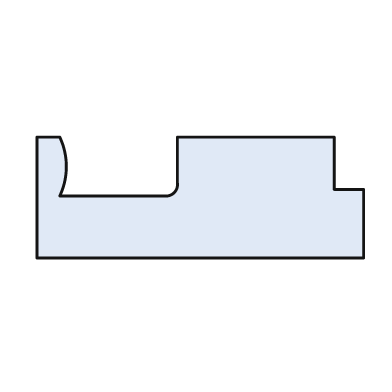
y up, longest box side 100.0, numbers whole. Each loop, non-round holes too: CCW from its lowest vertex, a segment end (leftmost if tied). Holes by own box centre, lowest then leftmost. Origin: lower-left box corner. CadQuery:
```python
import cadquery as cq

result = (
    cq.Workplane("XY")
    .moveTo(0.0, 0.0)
    .lineTo(100.0, 0.0)
    .lineTo(100.0, 21.0)
    .lineTo(91.0, 21.0)
    .lineTo(91.0, 37.0)
    .lineTo(43.0, 37.0)
    .lineTo(43.0, 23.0)
    .threePointArc((42.0, 20.0), (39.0, 19.0))
    .lineTo(7.0, 19.0)
    .threePointArc((9.0, 28.0), (7.0, 37.0))
    .lineTo(0.0, 37.0)
    .close()
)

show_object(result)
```